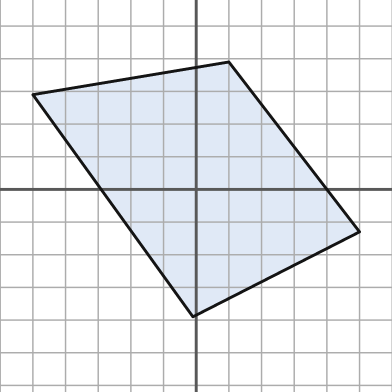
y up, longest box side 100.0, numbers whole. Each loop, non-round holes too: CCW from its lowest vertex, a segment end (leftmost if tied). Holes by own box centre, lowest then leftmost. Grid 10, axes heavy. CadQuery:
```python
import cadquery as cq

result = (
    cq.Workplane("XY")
    .moveTo(-1.0, -39.0)
    .lineTo(50.0, -13.0)
    .lineTo(10.0, 39.0)
    .lineTo(-50.0, 29.0)
    .close()
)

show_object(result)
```